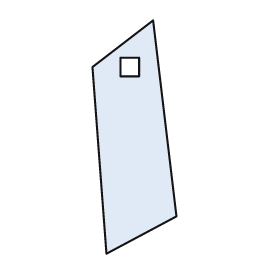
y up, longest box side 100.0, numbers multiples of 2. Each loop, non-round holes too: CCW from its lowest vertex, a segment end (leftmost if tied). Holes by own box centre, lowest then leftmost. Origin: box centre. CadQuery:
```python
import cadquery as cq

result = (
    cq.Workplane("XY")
    .moveTo(-12.0, -50.0)
    .lineTo(18.0, -34.0)
    .lineTo(8.0, 50.0)
    .lineTo(-18.0, 30.0)
    .close()
    .moveTo(-6.0, 26.0)
    .lineTo(2.0, 26.0)
    .lineTo(2.0, 34.0)
    .lineTo(-6.0, 34.0)
    .close()
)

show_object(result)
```